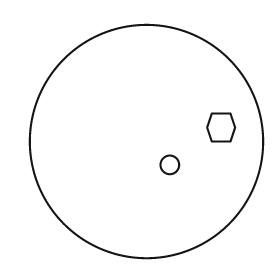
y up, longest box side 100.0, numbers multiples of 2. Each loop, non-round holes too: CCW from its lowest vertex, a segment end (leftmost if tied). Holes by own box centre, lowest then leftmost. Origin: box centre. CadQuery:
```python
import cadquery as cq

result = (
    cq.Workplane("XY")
    .moveTo(0.0, 0.0)
    .circle(50.0)
    .moveTo(10.0, -10.0)
    .circle(4.0)
    .moveTo(28.0, 0.0)
    .lineTo(36.0, 0.0)
    .lineTo(38.0, 6.0)
    .lineTo(36.0, 12.0)
    .lineTo(28.0, 12.0)
    .lineTo(26.0, 6.0)
    .close()
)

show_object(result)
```